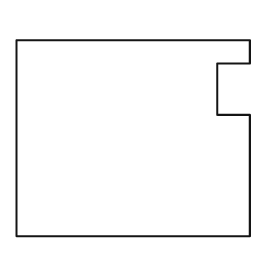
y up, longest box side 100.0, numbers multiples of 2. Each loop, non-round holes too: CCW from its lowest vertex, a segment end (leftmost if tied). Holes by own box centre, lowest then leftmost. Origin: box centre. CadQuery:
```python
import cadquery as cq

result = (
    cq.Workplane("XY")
    .moveTo(-50.0, -42.0)
    .lineTo(50.0, -42.0)
    .lineTo(50.0, 10.0)
    .lineTo(36.0, 10.0)
    .lineTo(36.0, 32.0)
    .lineTo(50.0, 32.0)
    .lineTo(50.0, 42.0)
    .lineTo(-50.0, 42.0)
    .close()
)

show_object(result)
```